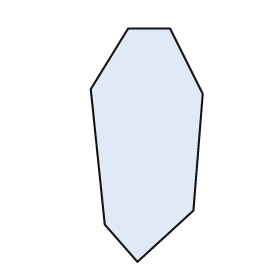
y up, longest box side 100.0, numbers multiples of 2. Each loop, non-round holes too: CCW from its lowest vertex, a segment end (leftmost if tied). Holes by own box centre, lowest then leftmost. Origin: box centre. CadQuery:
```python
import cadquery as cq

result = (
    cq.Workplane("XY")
    .moveTo(-4.0, -50.0)
    .lineTo(20.0, -28.0)
    .lineTo(24.0, 22.0)
    .lineTo(10.0, 50.0)
    .lineTo(-8.0, 50.0)
    .lineTo(-24.0, 24.0)
    .lineTo(-18.0, -34.0)
    .close()
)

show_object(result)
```